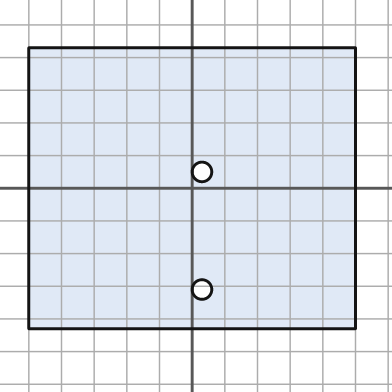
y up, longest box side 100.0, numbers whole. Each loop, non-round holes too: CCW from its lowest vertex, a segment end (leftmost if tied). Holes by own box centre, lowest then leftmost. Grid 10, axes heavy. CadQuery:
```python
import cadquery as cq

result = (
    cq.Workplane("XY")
    .moveTo(-50.0, -43.0)
    .lineTo(50.0, -43.0)
    .lineTo(50.0, 43.0)
    .lineTo(-50.0, 43.0)
    .close()
    .moveTo(3.0, -31.0)
    .circle(3.0)
    .moveTo(3.0, 5.0)
    .circle(3.0)
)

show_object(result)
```